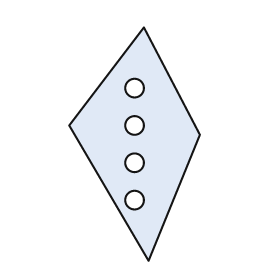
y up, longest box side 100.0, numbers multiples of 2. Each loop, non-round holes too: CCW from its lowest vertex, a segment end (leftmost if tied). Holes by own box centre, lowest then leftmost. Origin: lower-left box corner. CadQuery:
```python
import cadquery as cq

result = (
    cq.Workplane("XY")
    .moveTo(34.0, 0.0)
    .lineTo(56.0, 54.0)
    .lineTo(32.0, 100.0)
    .lineTo(0.0, 58.0)
    .close()
    .moveTo(28.0, 26.0)
    .circle(4.0)
    .moveTo(28.0, 42.0)
    .circle(4.0)
    .moveTo(28.0, 58.0)
    .circle(4.0)
    .moveTo(28.0, 74.0)
    .circle(4.0)
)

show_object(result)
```